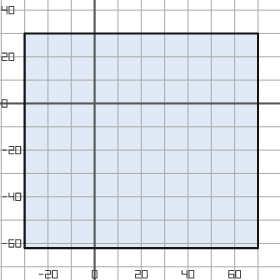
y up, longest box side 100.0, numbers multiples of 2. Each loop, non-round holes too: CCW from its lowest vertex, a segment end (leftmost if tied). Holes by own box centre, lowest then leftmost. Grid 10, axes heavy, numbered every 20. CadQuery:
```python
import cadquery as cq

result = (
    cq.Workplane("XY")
    .moveTo(-30.0, -62.0)
    .lineTo(70.0, -62.0)
    .lineTo(70.0, 30.0)
    .lineTo(-30.0, 30.0)
    .close()
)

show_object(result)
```